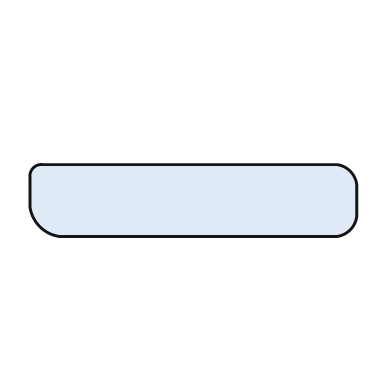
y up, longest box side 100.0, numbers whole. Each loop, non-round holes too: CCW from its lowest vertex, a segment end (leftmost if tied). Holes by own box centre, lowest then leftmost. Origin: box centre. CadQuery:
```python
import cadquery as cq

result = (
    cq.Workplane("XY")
    .moveTo(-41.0, -11.0)
    .lineTo(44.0, -11.0)
    .threePointArc((48.0, -9.0), (50.0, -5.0))
    .lineTo(50.0, 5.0)
    .threePointArc((48.0, 9.0), (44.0, 11.0))
    .lineTo(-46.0, 11.0)
    .threePointArc((-49.0, 10.0), (-50.0, 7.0))
    .lineTo(-50.0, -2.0)
    .threePointArc((-47.0, -8.0), (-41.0, -11.0))
    .close()
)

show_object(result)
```